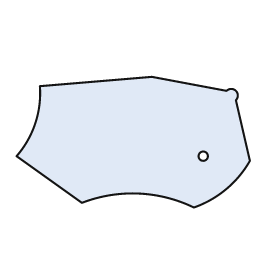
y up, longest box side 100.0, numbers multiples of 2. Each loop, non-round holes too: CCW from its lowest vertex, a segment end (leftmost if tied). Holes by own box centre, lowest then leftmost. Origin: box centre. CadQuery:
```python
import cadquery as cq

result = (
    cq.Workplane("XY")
    .moveTo(26.0, -28.0)
    .threePointArc((40.0, -20.0), (50.0, -8.0))
    .lineTo(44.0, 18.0)
    .threePointArc((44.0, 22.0), (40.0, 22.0))
    .lineTo(8.0, 28.0)
    .lineTo(-40.0, 24.0)
    .threePointArc((-42.0, 8.0), (-50.0, -6.0))
    .lineTo(-22.0, -26.0)
    .threePointArc((2.0, -22.0), (26.0, -28.0))
    .close()
    .moveTo(30.0, -6.0)
    .circle(2.0)
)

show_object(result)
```